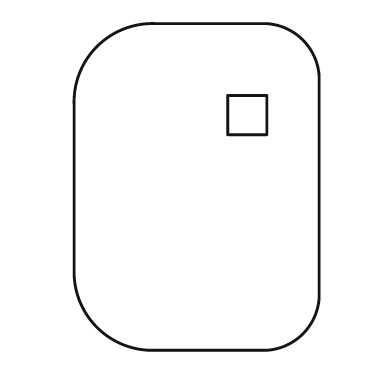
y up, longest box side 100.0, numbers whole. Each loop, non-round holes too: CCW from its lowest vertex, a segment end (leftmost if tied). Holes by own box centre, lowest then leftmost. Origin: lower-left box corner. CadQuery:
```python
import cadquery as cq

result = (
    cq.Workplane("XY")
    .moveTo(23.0, 0.0)
    .lineTo(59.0, 0.0)
    .threePointArc((70.0, 5.0), (75.0, 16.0))
    .lineTo(75.0, 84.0)
    .threePointArc((70.0, 95.0), (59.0, 100.0))
    .lineTo(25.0, 100.0)
    .threePointArc((7.0, 93.0), (0.0, 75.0))
    .lineTo(0.0, 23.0)
    .threePointArc((7.0, 7.0), (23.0, 0.0))
    .close()
    .moveTo(47.0, 66.0)
    .lineTo(59.0, 66.0)
    .lineTo(59.0, 78.0)
    .lineTo(47.0, 78.0)
    .close()
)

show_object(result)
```